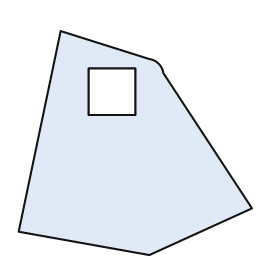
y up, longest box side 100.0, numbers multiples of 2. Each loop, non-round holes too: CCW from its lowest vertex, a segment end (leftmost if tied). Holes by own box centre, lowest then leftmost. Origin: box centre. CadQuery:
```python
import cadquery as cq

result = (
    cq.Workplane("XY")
    .moveTo(6.0, -48.0)
    .lineTo(50.0, -28.0)
    .lineTo(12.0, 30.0)
    .threePointArc((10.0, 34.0), (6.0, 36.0))
    .lineTo(-32.0, 48.0)
    .lineTo(-50.0, -38.0)
    .close()
    .moveTo(-20.0, 12.0)
    .lineTo(0.0, 12.0)
    .lineTo(0.0, 32.0)
    .lineTo(-20.0, 32.0)
    .close()
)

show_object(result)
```